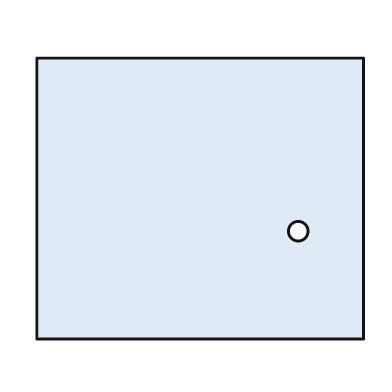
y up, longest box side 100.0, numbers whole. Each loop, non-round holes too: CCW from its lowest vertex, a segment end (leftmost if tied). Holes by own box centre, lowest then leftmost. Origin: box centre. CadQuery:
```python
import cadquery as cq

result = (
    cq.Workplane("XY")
    .moveTo(-50.0, -43.0)
    .lineTo(50.0, -43.0)
    .lineTo(50.0, 43.0)
    .lineTo(-50.0, 43.0)
    .close()
    .moveTo(30.0, -10.0)
    .circle(3.0)
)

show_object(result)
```